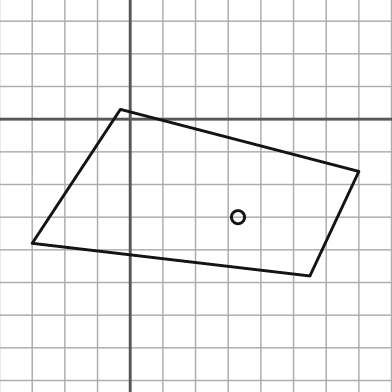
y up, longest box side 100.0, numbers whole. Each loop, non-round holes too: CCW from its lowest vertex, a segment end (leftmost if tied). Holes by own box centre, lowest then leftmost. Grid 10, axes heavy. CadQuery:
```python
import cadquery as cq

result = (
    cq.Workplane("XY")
    .moveTo(55.0, -48.0)
    .lineTo(70.0, -16.0)
    .lineTo(-3.0, 3.0)
    .lineTo(-30.0, -38.0)
    .close()
    .moveTo(33.0, -30.0)
    .circle(2.0)
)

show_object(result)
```